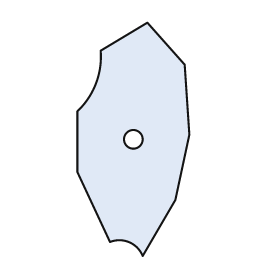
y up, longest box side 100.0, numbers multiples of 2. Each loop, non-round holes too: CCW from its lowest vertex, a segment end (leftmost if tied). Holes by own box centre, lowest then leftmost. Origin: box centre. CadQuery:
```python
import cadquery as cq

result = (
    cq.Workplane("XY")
    .moveTo(4.0, -50.0)
    .lineTo(18.0, -26.0)
    .lineTo(24.0, 2.0)
    .lineTo(22.0, 32.0)
    .lineTo(6.0, 50.0)
    .lineTo(-14.0, 38.0)
    .threePointArc((-16.0, 24.0), (-24.0, 12.0))
    .lineTo(-24.0, -14.0)
    .lineTo(-10.0, -44.0)
    .threePointArc((-2.0, -44.0), (4.0, -50.0))
    .close()
    .moveTo(0.0, 0.0)
    .circle(4.0)
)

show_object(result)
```